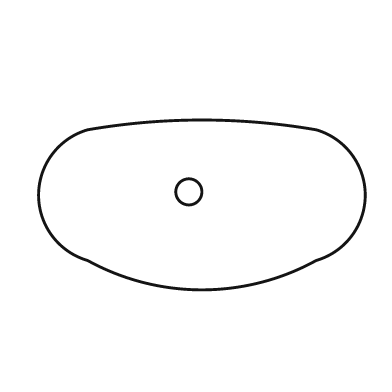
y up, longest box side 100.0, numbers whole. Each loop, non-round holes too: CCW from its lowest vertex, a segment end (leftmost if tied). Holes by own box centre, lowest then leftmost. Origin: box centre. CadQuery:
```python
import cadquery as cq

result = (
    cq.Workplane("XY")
    .moveTo(-35.0, -17.0)
    .threePointArc((0.0, -26.0), (35.0, -17.0))
    .threePointArc((50.0, 3.0), (35.0, 23.0))
    .threePointArc((0.0, 26.0), (-35.0, 23.0))
    .threePointArc((-50.0, 3.0), (-35.0, -17.0))
    .close()
    .moveTo(-4.0, 4.0)
    .circle(4.0)
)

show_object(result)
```